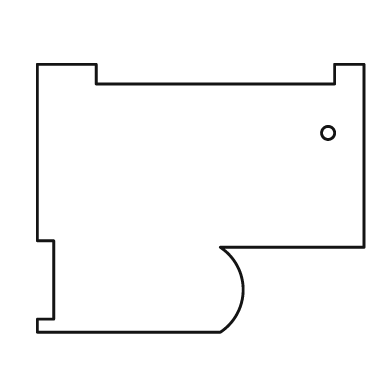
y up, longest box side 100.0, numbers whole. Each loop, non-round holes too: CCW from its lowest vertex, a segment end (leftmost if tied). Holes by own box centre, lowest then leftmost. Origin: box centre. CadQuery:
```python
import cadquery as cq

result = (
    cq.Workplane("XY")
    .moveTo(-50.0, -41.0)
    .lineTo(6.0, -41.0)
    .threePointArc((13.0, -28.0), (6.0, -15.0))
    .lineTo(50.0, -15.0)
    .lineTo(50.0, 41.0)
    .lineTo(41.0, 41.0)
    .lineTo(41.0, 35.0)
    .lineTo(-32.0, 35.0)
    .lineTo(-32.0, 41.0)
    .lineTo(-50.0, 41.0)
    .lineTo(-50.0, -13.0)
    .lineTo(-45.0, -13.0)
    .lineTo(-45.0, -37.0)
    .lineTo(-50.0, -37.0)
    .close()
    .moveTo(39.0, 20.0)
    .circle(2.0)
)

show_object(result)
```